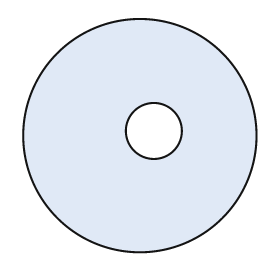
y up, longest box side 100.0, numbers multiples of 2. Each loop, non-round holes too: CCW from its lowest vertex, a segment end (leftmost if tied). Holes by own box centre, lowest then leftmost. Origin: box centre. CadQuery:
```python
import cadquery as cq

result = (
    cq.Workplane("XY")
    .moveTo(0.0, 0.0)
    .circle(50.0)
    .moveTo(6.0, 2.0)
    .circle(12.0)
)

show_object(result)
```